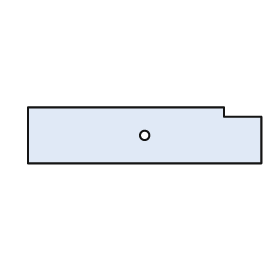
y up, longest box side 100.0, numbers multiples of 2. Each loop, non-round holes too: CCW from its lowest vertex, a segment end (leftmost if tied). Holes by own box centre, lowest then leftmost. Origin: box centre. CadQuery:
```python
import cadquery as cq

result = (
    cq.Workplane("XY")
    .moveTo(-50.0, -12.0)
    .lineTo(50.0, -12.0)
    .lineTo(50.0, 8.0)
    .lineTo(34.0, 8.0)
    .lineTo(34.0, 12.0)
    .lineTo(-50.0, 12.0)
    .close()
    .moveTo(0.0, 0.0)
    .circle(2.0)
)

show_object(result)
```